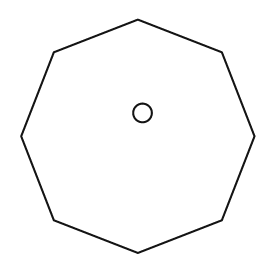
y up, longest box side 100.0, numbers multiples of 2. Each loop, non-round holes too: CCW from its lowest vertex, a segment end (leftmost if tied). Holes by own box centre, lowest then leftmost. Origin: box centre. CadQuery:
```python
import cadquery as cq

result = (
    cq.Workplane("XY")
    .moveTo(0.0, -50.0)
    .lineTo(36.0, -36.0)
    .lineTo(50.0, 0.0)
    .lineTo(36.0, 36.0)
    .lineTo(0.0, 50.0)
    .lineTo(-36.0, 36.0)
    .lineTo(-50.0, 0.0)
    .lineTo(-36.0, -36.0)
    .close()
    .moveTo(2.0, 10.0)
    .circle(4.0)
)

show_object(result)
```